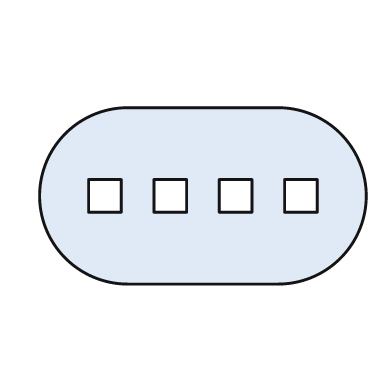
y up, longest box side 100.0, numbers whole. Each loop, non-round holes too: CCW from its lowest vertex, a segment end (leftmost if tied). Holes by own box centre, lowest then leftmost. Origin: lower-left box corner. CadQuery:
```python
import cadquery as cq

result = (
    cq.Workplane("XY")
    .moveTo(27.0, 0.0)
    .lineTo(73.0, 0.0)
    .threePointArc((100.0, 27.0), (73.0, 54.0))
    .lineTo(27.0, 54.0)
    .threePointArc((0.0, 27.0), (27.0, 0.0))
    .close()
    .moveTo(15.0, 22.0)
    .lineTo(25.0, 22.0)
    .lineTo(25.0, 32.0)
    .lineTo(15.0, 32.0)
    .close()
    .moveTo(35.0, 22.0)
    .lineTo(45.0, 22.0)
    .lineTo(45.0, 32.0)
    .lineTo(35.0, 32.0)
    .close()
    .moveTo(55.0, 22.0)
    .lineTo(65.0, 22.0)
    .lineTo(65.0, 32.0)
    .lineTo(55.0, 32.0)
    .close()
    .moveTo(75.0, 22.0)
    .lineTo(85.0, 22.0)
    .lineTo(85.0, 32.0)
    .lineTo(75.0, 32.0)
    .close()
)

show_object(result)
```